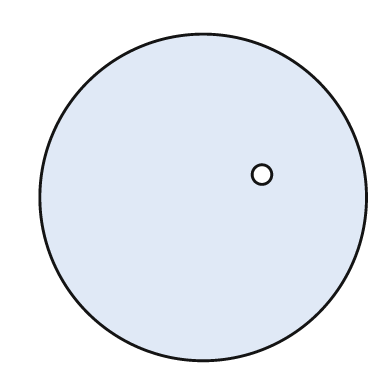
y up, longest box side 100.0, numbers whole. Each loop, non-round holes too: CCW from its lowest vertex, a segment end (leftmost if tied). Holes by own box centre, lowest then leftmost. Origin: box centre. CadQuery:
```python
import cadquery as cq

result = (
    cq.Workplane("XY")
    .moveTo(0.0, 0.0)
    .circle(50.0)
    .moveTo(18.0, 7.0)
    .circle(3.0)
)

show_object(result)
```